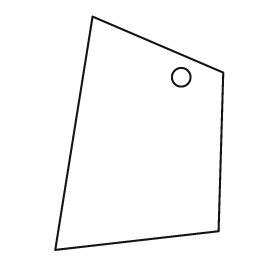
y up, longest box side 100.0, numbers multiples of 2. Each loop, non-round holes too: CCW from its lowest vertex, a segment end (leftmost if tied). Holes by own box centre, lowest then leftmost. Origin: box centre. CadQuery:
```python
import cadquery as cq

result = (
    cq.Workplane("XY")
    .moveTo(-36.0, -50.0)
    .lineTo(34.0, -42.0)
    .lineTo(36.0, 26.0)
    .lineTo(-20.0, 50.0)
    .close()
    .moveTo(18.0, 24.0)
    .circle(4.0)
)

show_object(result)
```